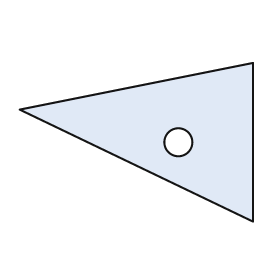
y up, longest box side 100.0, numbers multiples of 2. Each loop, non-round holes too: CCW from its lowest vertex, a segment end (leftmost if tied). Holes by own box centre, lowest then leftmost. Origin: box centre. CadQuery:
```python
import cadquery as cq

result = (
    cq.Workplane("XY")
    .moveTo(50.0, -34.0)
    .lineTo(50.0, 34.0)
    .lineTo(-50.0, 14.0)
    .close()
    .moveTo(18.0, 0.0)
    .circle(6.0)
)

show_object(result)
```